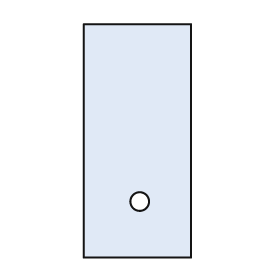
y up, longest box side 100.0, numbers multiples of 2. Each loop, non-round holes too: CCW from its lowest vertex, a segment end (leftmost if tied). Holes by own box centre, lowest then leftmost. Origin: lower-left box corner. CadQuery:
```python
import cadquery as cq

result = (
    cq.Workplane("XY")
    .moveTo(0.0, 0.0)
    .lineTo(46.0, 0.0)
    .lineTo(46.0, 100.0)
    .lineTo(0.0, 100.0)
    .close()
    .moveTo(24.0, 24.0)
    .circle(4.0)
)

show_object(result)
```